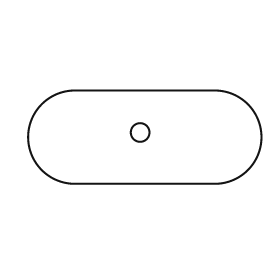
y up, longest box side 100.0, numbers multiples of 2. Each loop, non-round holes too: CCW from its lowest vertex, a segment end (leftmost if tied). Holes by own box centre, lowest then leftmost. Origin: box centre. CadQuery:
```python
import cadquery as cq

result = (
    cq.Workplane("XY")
    .moveTo(-30.0, -20.0)
    .lineTo(30.0, -20.0)
    .threePointArc((50.0, 0.0), (30.0, 20.0))
    .lineTo(-30.0, 20.0)
    .threePointArc((-50.0, 0.0), (-30.0, -20.0))
    .close()
    .moveTo(-2.0, 2.0)
    .circle(4.0)
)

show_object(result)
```